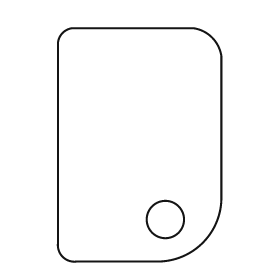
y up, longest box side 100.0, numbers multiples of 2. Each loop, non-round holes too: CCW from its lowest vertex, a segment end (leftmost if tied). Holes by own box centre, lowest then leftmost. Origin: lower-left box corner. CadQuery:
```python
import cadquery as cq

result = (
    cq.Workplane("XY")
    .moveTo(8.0, 0.0)
    .lineTo(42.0, 0.0)
    .threePointArc((62.0, 8.0), (70.0, 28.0))
    .lineTo(70.0, 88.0)
    .threePointArc((66.0, 96.0), (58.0, 100.0))
    .lineTo(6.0, 100.0)
    .threePointArc((2.0, 98.0), (0.0, 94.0))
    .lineTo(0.0, 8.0)
    .threePointArc((2.0, 2.0), (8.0, 0.0))
    .close()
    .moveTo(46.0, 18.0)
    .circle(8.0)
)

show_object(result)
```